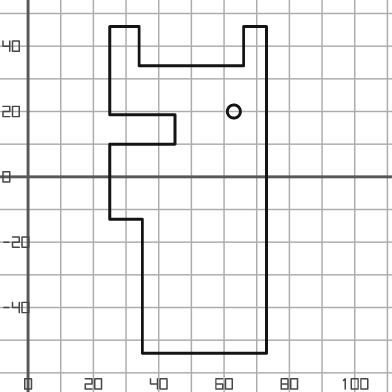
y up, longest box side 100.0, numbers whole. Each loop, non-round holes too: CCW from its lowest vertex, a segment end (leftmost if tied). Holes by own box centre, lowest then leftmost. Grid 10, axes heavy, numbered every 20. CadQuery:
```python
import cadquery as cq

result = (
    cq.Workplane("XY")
    .moveTo(35.0, -54.0)
    .lineTo(73.0, -54.0)
    .lineTo(73.0, 46.0)
    .lineTo(66.0, 46.0)
    .lineTo(66.0, 34.0)
    .lineTo(34.0, 34.0)
    .lineTo(34.0, 46.0)
    .lineTo(25.0, 46.0)
    .lineTo(25.0, 19.0)
    .lineTo(45.0, 19.0)
    .lineTo(45.0, 10.0)
    .lineTo(25.0, 10.0)
    .lineTo(25.0, -13.0)
    .lineTo(35.0, -13.0)
    .close()
    .moveTo(63.0, 20.0)
    .circle(2.0)
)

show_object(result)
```